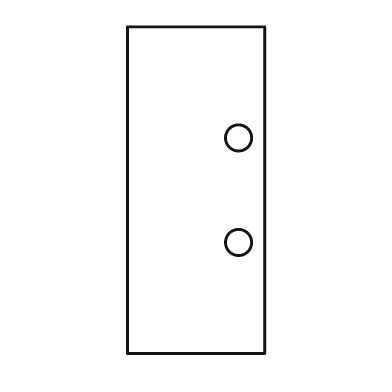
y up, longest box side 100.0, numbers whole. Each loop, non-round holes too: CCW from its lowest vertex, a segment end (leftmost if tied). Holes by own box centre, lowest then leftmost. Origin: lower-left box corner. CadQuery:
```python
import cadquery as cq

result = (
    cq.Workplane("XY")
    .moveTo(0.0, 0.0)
    .lineTo(42.0, 0.0)
    .lineTo(42.0, 100.0)
    .lineTo(0.0, 100.0)
    .close()
    .moveTo(34.0, 34.0)
    .circle(4.0)
    .moveTo(34.0, 66.0)
    .circle(4.0)
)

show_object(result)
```